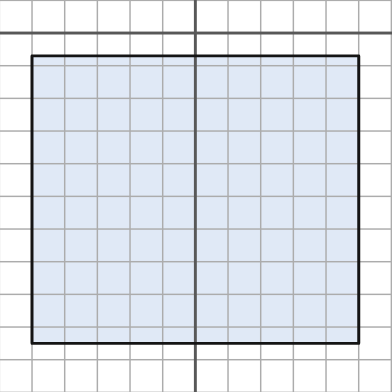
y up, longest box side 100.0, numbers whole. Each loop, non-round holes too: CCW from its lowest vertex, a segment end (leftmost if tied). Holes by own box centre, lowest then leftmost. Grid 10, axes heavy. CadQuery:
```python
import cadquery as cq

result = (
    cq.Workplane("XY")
    .moveTo(-50.0, -95.0)
    .lineTo(50.0, -95.0)
    .lineTo(50.0, -7.0)
    .lineTo(-50.0, -7.0)
    .close()
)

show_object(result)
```